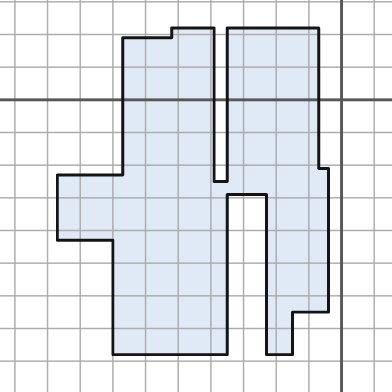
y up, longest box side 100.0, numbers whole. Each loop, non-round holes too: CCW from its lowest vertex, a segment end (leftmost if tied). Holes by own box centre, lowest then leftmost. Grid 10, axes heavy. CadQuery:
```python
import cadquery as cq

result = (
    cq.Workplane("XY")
    .moveTo(-70.0, -78.0)
    .lineTo(-35.0, -78.0)
    .lineTo(-35.0, -29.0)
    .lineTo(-23.0, -29.0)
    .lineTo(-23.0, -78.0)
    .lineTo(-15.0, -78.0)
    .lineTo(-15.0, -65.0)
    .lineTo(-4.0, -65.0)
    .lineTo(-4.0, -21.0)
    .lineTo(-7.0, -21.0)
    .lineTo(-7.0, 22.0)
    .lineTo(-35.0, 22.0)
    .lineTo(-35.0, -25.0)
    .lineTo(-39.0, -25.0)
    .lineTo(-39.0, 22.0)
    .lineTo(-52.0, 22.0)
    .lineTo(-52.0, 19.0)
    .lineTo(-67.0, 19.0)
    .lineTo(-67.0, -23.0)
    .lineTo(-87.0, -23.0)
    .lineTo(-87.0, -43.0)
    .lineTo(-70.0, -43.0)
    .close()
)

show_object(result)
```